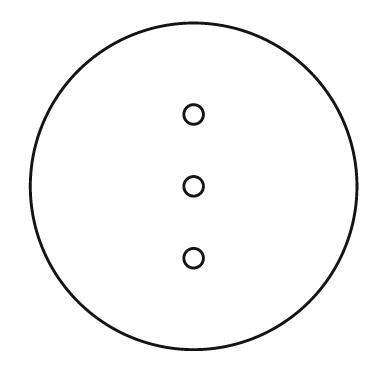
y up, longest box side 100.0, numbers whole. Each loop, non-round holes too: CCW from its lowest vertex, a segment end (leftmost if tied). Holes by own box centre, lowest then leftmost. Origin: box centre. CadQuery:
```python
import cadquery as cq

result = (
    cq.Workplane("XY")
    .moveTo(0.0, 0.0)
    .circle(50.0)
    .moveTo(0.0, -22.0)
    .circle(3.0)
    .moveTo(0.0, 0.0)
    .circle(3.0)
    .moveTo(0.0, 22.0)
    .circle(3.0)
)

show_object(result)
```